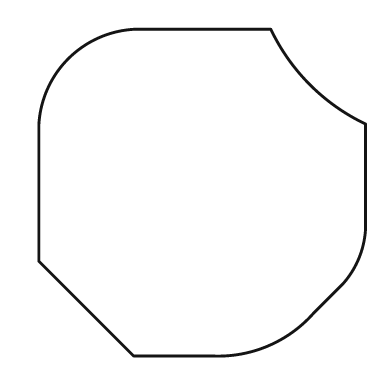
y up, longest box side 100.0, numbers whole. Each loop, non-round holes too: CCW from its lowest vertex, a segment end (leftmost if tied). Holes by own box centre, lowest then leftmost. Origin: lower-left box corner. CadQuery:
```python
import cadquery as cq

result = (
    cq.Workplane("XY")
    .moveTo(29.0, 0.0)
    .lineTo(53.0, 0.0)
    .threePointArc((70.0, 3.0), (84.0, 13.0))
    .lineTo(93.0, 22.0)
    .threePointArc((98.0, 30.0), (100.0, 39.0))
    .lineTo(100.0, 71.0)
    .threePointArc((83.0, 83.0), (71.0, 100.0))
    .lineTo(29.0, 100.0)
    .threePointArc((9.0, 91.0), (0.0, 71.0))
    .lineTo(0.0, 29.0)
    .close()
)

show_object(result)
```